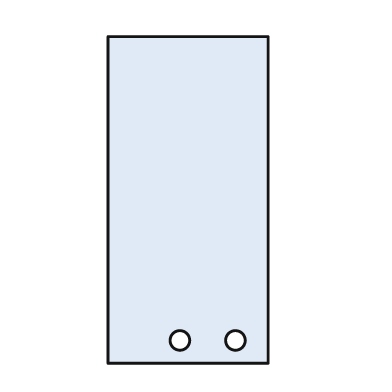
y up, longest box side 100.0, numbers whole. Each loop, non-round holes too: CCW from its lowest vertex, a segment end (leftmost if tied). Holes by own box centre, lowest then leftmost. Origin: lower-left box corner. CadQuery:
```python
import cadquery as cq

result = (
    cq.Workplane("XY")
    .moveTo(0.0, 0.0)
    .lineTo(49.0, 0.0)
    .lineTo(49.0, 100.0)
    .lineTo(0.0, 100.0)
    .close()
    .moveTo(22.0, 7.0)
    .circle(3.0)
    .moveTo(39.0, 7.0)
    .circle(3.0)
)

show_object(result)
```